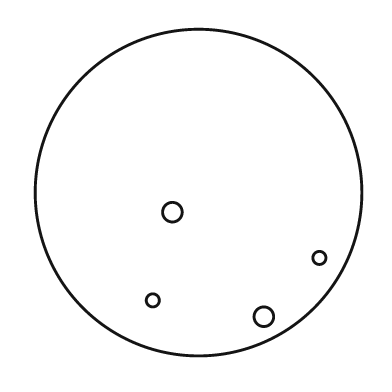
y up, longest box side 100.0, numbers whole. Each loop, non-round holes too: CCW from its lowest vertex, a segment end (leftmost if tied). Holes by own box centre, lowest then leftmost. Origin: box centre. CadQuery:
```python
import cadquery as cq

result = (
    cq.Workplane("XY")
    .moveTo(0.0, 0.0)
    .circle(50.0)
    .moveTo(20.0, -38.0)
    .circle(3.0)
    .moveTo(-14.0, -33.0)
    .circle(2.0)
    .moveTo(37.0, -20.0)
    .circle(2.0)
    .moveTo(-8.0, -6.0)
    .circle(3.0)
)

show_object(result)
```